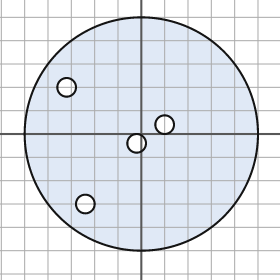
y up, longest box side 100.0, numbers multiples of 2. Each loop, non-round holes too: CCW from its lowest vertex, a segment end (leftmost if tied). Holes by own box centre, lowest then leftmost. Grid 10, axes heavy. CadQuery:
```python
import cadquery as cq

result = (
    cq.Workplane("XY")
    .moveTo(0.0, 0.0)
    .circle(50.0)
    .moveTo(-24.0, -30.0)
    .circle(4.0)
    .moveTo(-2.0, -4.0)
    .circle(4.0)
    .moveTo(10.0, 4.0)
    .circle(4.0)
    .moveTo(-32.0, 20.0)
    .circle(4.0)
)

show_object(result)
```